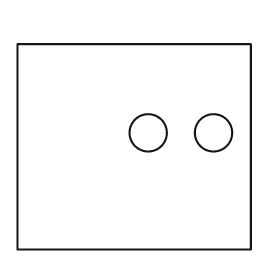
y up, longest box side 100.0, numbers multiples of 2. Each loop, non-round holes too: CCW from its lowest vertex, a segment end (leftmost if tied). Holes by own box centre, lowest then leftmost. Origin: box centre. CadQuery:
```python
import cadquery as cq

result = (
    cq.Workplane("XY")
    .moveTo(-50.0, -44.0)
    .lineTo(50.0, -44.0)
    .lineTo(50.0, 44.0)
    .lineTo(-50.0, 44.0)
    .close()
    .moveTo(6.0, 6.0)
    .circle(8.0)
    .moveTo(34.0, 6.0)
    .circle(8.0)
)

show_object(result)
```